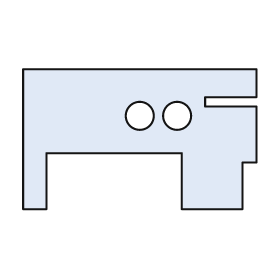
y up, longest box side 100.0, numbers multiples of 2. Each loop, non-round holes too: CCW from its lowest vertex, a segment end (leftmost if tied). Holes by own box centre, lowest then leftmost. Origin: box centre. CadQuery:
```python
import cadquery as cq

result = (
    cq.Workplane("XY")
    .moveTo(-50.0, -30.0)
    .lineTo(-40.0, -30.0)
    .lineTo(-40.0, -6.0)
    .lineTo(18.0, -6.0)
    .lineTo(18.0, -30.0)
    .lineTo(44.0, -30.0)
    .lineTo(44.0, -10.0)
    .lineTo(50.0, -10.0)
    .lineTo(50.0, 14.0)
    .lineTo(28.0, 14.0)
    .lineTo(28.0, 18.0)
    .lineTo(50.0, 18.0)
    .lineTo(50.0, 30.0)
    .lineTo(-50.0, 30.0)
    .close()
    .moveTo(0.0, 10.0)
    .circle(6.0)
    .moveTo(16.0, 10.0)
    .circle(6.0)
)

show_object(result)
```